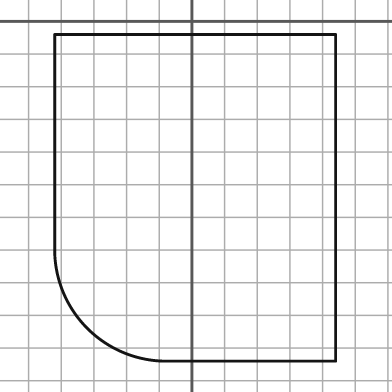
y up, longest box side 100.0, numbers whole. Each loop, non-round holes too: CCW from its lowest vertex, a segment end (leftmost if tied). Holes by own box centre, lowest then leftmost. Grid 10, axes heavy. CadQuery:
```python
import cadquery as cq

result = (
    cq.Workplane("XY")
    .moveTo(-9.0, -104.0)
    .lineTo(44.0, -104.0)
    .lineTo(44.0, -4.0)
    .lineTo(-42.0, -4.0)
    .lineTo(-42.0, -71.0)
    .threePointArc((-32.0, -94.0), (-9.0, -104.0))
    .close()
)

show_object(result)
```